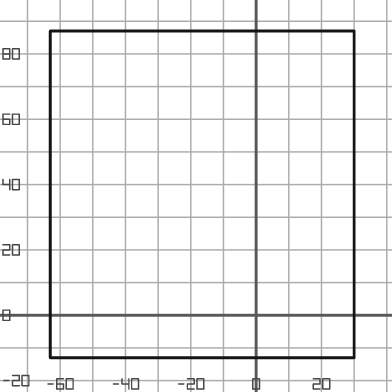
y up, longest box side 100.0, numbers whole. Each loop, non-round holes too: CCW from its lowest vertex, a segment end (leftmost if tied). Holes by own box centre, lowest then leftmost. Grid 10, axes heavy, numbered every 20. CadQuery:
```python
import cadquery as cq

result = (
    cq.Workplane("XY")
    .moveTo(-63.0, -13.0)
    .lineTo(30.0, -13.0)
    .lineTo(30.0, 87.0)
    .lineTo(-63.0, 87.0)
    .close()
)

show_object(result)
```